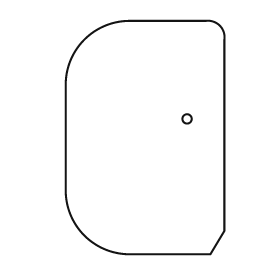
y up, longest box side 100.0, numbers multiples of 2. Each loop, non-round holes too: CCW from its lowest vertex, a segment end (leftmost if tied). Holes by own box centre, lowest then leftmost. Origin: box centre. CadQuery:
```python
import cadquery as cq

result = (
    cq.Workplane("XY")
    .moveTo(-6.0, -50.0)
    .lineTo(28.0, -50.0)
    .lineTo(34.0, -40.0)
    .lineTo(34.0, 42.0)
    .threePointArc((32.0, 48.0), (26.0, 50.0))
    .lineTo(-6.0, 50.0)
    .threePointArc((-26.0, 42.0), (-34.0, 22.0))
    .lineTo(-34.0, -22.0)
    .threePointArc((-26.0, -42.0), (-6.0, -50.0))
    .close()
    .moveTo(18.0, 8.0)
    .circle(2.0)
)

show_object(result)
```